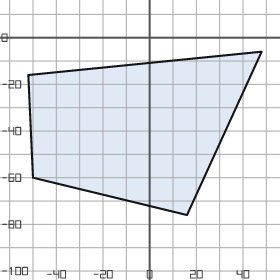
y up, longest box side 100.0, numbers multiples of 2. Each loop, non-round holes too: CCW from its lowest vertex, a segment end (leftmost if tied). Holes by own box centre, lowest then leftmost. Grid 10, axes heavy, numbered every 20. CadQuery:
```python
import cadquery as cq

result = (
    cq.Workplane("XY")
    .moveTo(16.0, -76.0)
    .lineTo(48.0, -6.0)
    .lineTo(-52.0, -16.0)
    .lineTo(-50.0, -60.0)
    .close()
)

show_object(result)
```